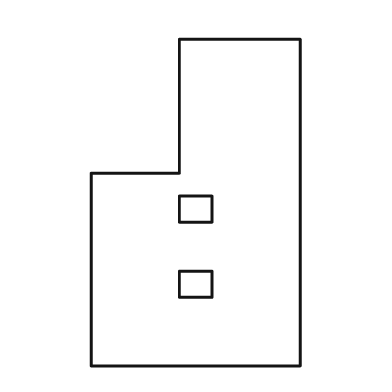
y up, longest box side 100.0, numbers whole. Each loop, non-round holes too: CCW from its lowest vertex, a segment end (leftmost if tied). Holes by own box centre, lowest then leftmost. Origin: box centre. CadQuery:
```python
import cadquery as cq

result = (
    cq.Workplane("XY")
    .moveTo(-32.0, -50.0)
    .lineTo(32.0, -50.0)
    .lineTo(32.0, 50.0)
    .lineTo(-5.0, 50.0)
    .lineTo(-5.0, 9.0)
    .lineTo(-32.0, 9.0)
    .close()
    .moveTo(-5.0, -29.0)
    .lineTo(5.0, -29.0)
    .lineTo(5.0, -21.0)
    .lineTo(-5.0, -21.0)
    .close()
    .moveTo(-5.0, -6.0)
    .lineTo(5.0, -6.0)
    .lineTo(5.0, 2.0)
    .lineTo(-5.0, 2.0)
    .close()
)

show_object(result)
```